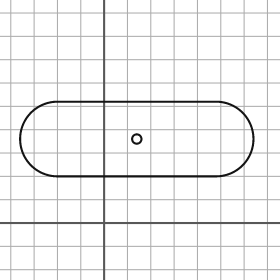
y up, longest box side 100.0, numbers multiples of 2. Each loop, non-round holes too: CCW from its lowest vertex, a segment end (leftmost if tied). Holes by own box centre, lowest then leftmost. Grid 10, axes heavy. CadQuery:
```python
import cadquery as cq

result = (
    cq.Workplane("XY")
    .moveTo(-20.0, 20.0)
    .lineTo(48.0, 20.0)
    .threePointArc((64.0, 36.0), (48.0, 52.0))
    .lineTo(-20.0, 52.0)
    .threePointArc((-36.0, 36.0), (-20.0, 20.0))
    .close()
    .moveTo(14.0, 36.0)
    .circle(2.0)
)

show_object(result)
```